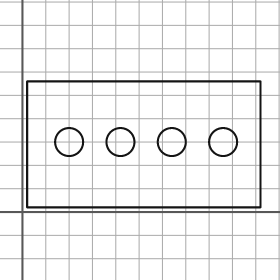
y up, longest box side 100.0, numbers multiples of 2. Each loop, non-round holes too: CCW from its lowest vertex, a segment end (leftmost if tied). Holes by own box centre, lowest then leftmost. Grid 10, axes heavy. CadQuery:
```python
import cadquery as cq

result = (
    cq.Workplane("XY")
    .moveTo(2.0, 2.0)
    .lineTo(102.0, 2.0)
    .lineTo(102.0, 56.0)
    .lineTo(2.0, 56.0)
    .close()
    .moveTo(20.0, 30.0)
    .circle(6.0)
    .moveTo(42.0, 30.0)
    .circle(6.0)
    .moveTo(64.0, 30.0)
    .circle(6.0)
    .moveTo(86.0, 30.0)
    .circle(6.0)
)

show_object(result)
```